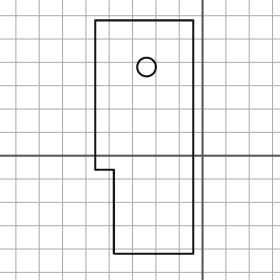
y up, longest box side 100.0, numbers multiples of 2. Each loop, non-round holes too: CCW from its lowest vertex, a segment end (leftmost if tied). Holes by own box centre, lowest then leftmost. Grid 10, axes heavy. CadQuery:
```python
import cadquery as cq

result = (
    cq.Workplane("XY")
    .moveTo(-38.0, -42.0)
    .lineTo(-4.0, -42.0)
    .lineTo(-4.0, 58.0)
    .lineTo(-46.0, 58.0)
    .lineTo(-46.0, -6.0)
    .lineTo(-38.0, -6.0)
    .close()
    .moveTo(-24.0, 38.0)
    .circle(4.0)
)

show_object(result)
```